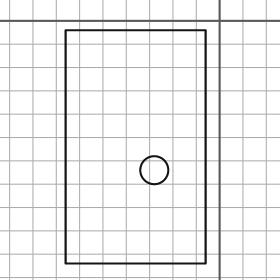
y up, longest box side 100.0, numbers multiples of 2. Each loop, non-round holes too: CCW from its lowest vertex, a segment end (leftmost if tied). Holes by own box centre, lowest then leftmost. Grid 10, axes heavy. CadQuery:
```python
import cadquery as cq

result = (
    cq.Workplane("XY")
    .moveTo(-66.0, -104.0)
    .lineTo(-6.0, -104.0)
    .lineTo(-6.0, -4.0)
    .lineTo(-66.0, -4.0)
    .close()
    .moveTo(-28.0, -64.0)
    .circle(6.0)
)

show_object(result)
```